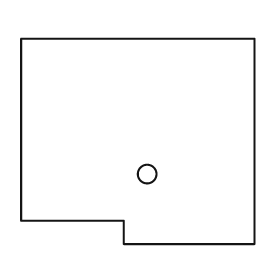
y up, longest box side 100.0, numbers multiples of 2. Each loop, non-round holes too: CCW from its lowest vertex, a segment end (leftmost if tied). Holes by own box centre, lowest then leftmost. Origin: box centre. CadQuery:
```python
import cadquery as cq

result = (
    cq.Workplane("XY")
    .moveTo(-6.0, -44.0)
    .lineTo(50.0, -44.0)
    .lineTo(50.0, 44.0)
    .lineTo(-50.0, 44.0)
    .lineTo(-50.0, -34.0)
    .lineTo(-6.0, -34.0)
    .close()
    .moveTo(4.0, -14.0)
    .circle(4.0)
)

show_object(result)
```